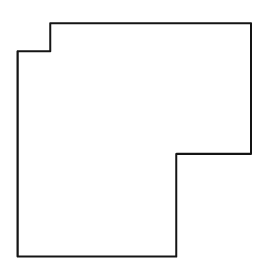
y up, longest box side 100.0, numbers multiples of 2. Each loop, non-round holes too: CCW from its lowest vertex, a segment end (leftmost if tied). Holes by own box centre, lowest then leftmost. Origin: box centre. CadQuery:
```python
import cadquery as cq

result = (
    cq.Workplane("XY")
    .moveTo(-50.0, -50.0)
    .lineTo(18.0, -50.0)
    .lineTo(18.0, -6.0)
    .lineTo(50.0, -6.0)
    .lineTo(50.0, 50.0)
    .lineTo(-36.0, 50.0)
    .lineTo(-36.0, 38.0)
    .lineTo(-50.0, 38.0)
    .close()
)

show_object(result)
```